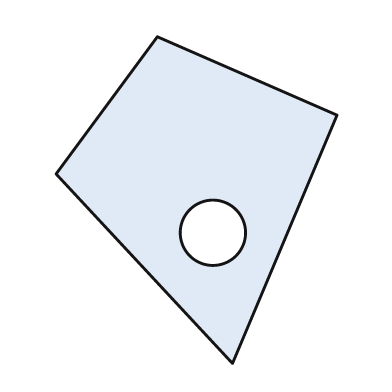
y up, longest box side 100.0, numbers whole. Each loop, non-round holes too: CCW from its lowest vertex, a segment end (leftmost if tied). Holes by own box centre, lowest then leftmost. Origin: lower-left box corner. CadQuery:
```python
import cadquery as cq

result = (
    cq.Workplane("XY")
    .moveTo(54.0, 0.0)
    .lineTo(86.0, 76.0)
    .lineTo(31.0, 100.0)
    .lineTo(0.0, 58.0)
    .close()
    .moveTo(48.0, 40.0)
    .circle(10.0)
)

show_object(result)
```